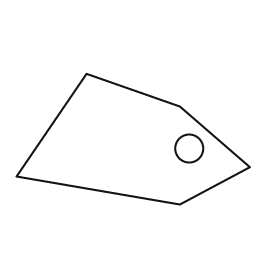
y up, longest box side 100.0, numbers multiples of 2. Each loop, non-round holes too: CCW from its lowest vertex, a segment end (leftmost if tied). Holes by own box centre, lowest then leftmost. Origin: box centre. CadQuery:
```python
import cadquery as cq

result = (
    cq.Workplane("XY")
    .moveTo(20.0, -28.0)
    .lineTo(50.0, -12.0)
    .lineTo(20.0, 14.0)
    .lineTo(-20.0, 28.0)
    .lineTo(-50.0, -16.0)
    .close()
    .moveTo(24.0, -4.0)
    .circle(6.0)
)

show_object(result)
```